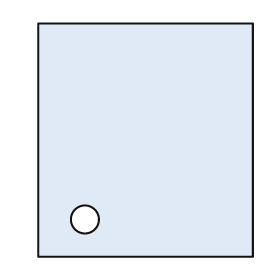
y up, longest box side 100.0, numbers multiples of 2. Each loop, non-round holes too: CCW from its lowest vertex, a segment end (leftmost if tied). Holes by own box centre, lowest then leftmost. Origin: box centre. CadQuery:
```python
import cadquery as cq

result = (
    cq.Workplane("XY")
    .moveTo(-46.0, -50.0)
    .lineTo(46.0, -50.0)
    .lineTo(46.0, 50.0)
    .lineTo(-46.0, 50.0)
    .close()
    .moveTo(-26.0, -34.0)
    .circle(6.0)
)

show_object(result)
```